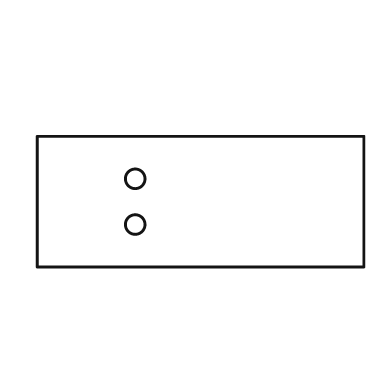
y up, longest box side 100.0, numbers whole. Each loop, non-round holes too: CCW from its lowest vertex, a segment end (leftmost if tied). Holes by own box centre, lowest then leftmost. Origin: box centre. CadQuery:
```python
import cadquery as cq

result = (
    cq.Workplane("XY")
    .moveTo(-50.0, -20.0)
    .lineTo(50.0, -20.0)
    .lineTo(50.0, 20.0)
    .lineTo(-50.0, 20.0)
    .close()
    .moveTo(-20.0, -7.0)
    .circle(3.0)
    .moveTo(-20.0, 7.0)
    .circle(3.0)
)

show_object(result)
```